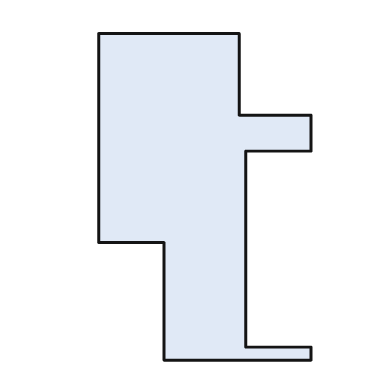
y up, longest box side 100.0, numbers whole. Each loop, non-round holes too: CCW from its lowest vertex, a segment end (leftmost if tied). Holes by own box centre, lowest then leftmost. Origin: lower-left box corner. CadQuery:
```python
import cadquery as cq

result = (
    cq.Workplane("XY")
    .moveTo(20.0, 0.0)
    .lineTo(65.0, 0.0)
    .lineTo(65.0, 4.0)
    .lineTo(45.0, 4.0)
    .lineTo(45.0, 64.0)
    .lineTo(65.0, 64.0)
    .lineTo(65.0, 75.0)
    .lineTo(43.0, 75.0)
    .lineTo(43.0, 100.0)
    .lineTo(0.0, 100.0)
    .lineTo(0.0, 36.0)
    .lineTo(20.0, 36.0)
    .close()
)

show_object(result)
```